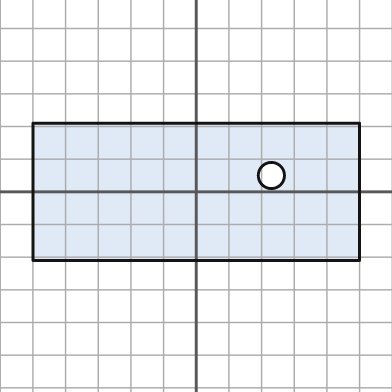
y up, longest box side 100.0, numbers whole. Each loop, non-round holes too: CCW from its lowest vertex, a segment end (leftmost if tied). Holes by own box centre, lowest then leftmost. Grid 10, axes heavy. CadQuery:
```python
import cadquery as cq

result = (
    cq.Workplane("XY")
    .moveTo(-50.0, -21.0)
    .lineTo(50.0, -21.0)
    .lineTo(50.0, 21.0)
    .lineTo(-50.0, 21.0)
    .close()
    .moveTo(23.0, 5.0)
    .circle(4.0)
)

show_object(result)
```